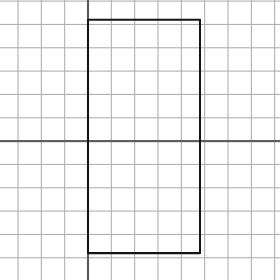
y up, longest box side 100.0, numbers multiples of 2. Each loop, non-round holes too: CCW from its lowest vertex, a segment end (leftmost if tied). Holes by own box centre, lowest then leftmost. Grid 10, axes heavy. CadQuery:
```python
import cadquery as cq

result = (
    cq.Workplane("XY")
    .moveTo(0.0, -48.0)
    .lineTo(48.0, -48.0)
    .lineTo(48.0, 52.0)
    .lineTo(0.0, 52.0)
    .close()
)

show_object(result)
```